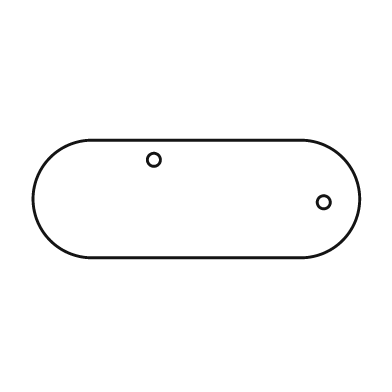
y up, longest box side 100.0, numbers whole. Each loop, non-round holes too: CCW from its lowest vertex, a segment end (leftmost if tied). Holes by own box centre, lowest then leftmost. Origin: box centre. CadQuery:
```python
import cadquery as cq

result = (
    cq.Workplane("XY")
    .moveTo(-32.0, -18.0)
    .lineTo(32.0, -18.0)
    .threePointArc((50.0, 0.0), (32.0, 18.0))
    .lineTo(-32.0, 18.0)
    .threePointArc((-50.0, 0.0), (-32.0, -18.0))
    .close()
    .moveTo(39.0, -1.0)
    .circle(2.0)
    .moveTo(-13.0, 12.0)
    .circle(2.0)
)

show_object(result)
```